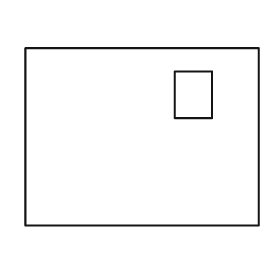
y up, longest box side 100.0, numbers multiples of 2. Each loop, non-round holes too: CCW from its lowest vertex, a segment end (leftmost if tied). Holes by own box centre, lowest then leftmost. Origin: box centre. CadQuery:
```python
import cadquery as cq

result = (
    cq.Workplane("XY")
    .moveTo(-50.0, -38.0)
    .lineTo(50.0, -38.0)
    .lineTo(50.0, 38.0)
    .lineTo(-50.0, 38.0)
    .close()
    .moveTo(14.0, 8.0)
    .lineTo(30.0, 8.0)
    .lineTo(30.0, 28.0)
    .lineTo(14.0, 28.0)
    .close()
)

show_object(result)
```